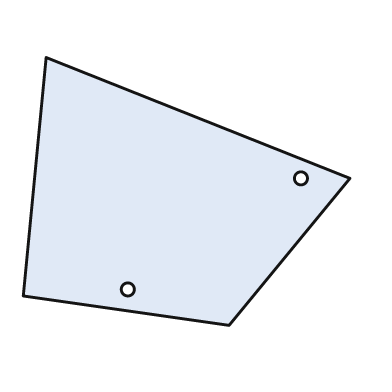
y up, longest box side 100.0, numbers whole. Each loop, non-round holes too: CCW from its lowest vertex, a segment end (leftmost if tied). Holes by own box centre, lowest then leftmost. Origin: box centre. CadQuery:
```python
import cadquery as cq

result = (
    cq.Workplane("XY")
    .moveTo(13.0, -41.0)
    .lineTo(50.0, 4.0)
    .lineTo(-43.0, 41.0)
    .lineTo(-50.0, -32.0)
    .close()
    .moveTo(-18.0, -30.0)
    .circle(2.0)
    .moveTo(35.0, 4.0)
    .circle(2.0)
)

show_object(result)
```